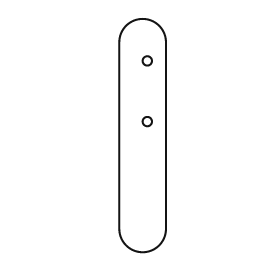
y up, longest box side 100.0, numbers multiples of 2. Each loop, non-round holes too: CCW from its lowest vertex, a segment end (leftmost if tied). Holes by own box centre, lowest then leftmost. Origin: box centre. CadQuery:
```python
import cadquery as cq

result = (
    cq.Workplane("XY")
    .moveTo(-10.0, -40.0)
    .threePointArc((0.0, -50.0), (10.0, -40.0))
    .lineTo(10.0, 40.0)
    .threePointArc((0.0, 50.0), (-10.0, 40.0))
    .close()
    .moveTo(2.0, 6.0)
    .circle(2.0)
    .moveTo(2.0, 32.0)
    .circle(2.0)
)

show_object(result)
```